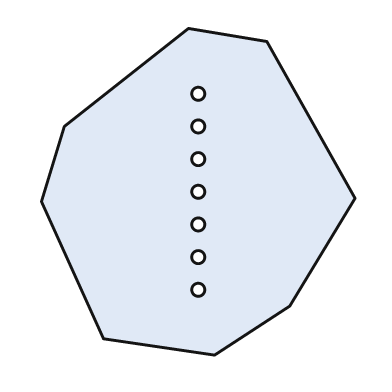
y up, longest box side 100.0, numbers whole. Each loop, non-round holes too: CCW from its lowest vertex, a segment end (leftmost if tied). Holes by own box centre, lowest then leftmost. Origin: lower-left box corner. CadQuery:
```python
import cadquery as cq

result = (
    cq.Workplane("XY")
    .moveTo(53.0, 0.0)
    .lineTo(76.0, 15.0)
    .lineTo(96.0, 48.0)
    .lineTo(69.0, 96.0)
    .lineTo(45.0, 100.0)
    .lineTo(7.0, 70.0)
    .lineTo(0.0, 47.0)
    .lineTo(19.0, 5.0)
    .close()
    .moveTo(48.0, 20.0)
    .circle(2.0)
    .moveTo(48.0, 30.0)
    .circle(2.0)
    .moveTo(48.0, 40.0)
    .circle(2.0)
    .moveTo(48.0, 50.0)
    .circle(2.0)
    .moveTo(48.0, 60.0)
    .circle(2.0)
    .moveTo(48.0, 70.0)
    .circle(2.0)
    .moveTo(48.0, 80.0)
    .circle(2.0)
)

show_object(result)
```